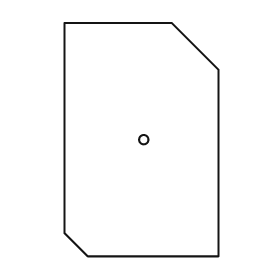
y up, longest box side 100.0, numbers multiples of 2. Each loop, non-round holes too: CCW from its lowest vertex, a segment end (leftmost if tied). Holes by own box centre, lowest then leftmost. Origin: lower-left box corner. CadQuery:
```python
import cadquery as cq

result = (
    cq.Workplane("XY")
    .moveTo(10.0, 0.0)
    .lineTo(66.0, 0.0)
    .lineTo(66.0, 80.0)
    .lineTo(46.0, 100.0)
    .lineTo(0.0, 100.0)
    .lineTo(0.0, 10.0)
    .close()
    .moveTo(34.0, 50.0)
    .circle(2.0)
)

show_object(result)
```